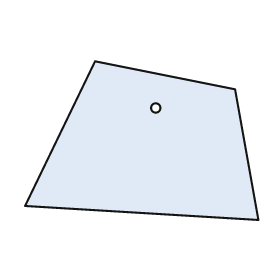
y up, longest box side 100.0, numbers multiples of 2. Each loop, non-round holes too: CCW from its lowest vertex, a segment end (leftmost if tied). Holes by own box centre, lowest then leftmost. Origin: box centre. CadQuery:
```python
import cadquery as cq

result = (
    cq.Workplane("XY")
    .moveTo(50.0, -34.0)
    .lineTo(40.0, 22.0)
    .lineTo(-20.0, 34.0)
    .lineTo(-50.0, -28.0)
    .close()
    .moveTo(6.0, 14.0)
    .circle(2.0)
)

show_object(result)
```